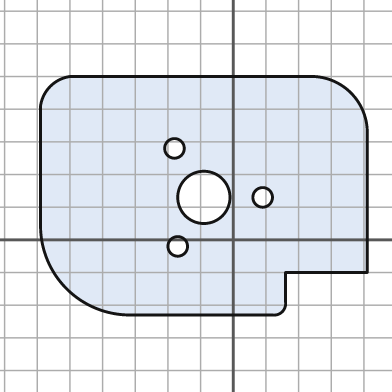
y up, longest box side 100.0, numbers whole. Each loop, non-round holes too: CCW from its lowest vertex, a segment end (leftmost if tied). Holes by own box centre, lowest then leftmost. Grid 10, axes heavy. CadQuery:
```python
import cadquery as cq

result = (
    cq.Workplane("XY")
    .moveTo(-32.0, -23.0)
    .lineTo(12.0, -23.0)
    .threePointArc((15.0, -22.0), (16.0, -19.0))
    .lineTo(16.0, -10.0)
    .lineTo(41.0, -10.0)
    .lineTo(41.0, 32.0)
    .threePointArc((36.0, 45.0), (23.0, 50.0))
    .lineTo(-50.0, 50.0)
    .threePointArc((-56.0, 47.0), (-59.0, 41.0))
    .lineTo(-59.0, 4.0)
    .threePointArc((-51.0, -15.0), (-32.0, -23.0))
    .close()
    .moveTo(-17.0, -2.0)
    .circle(3.0)
    .moveTo(-9.0, 13.0)
    .circle(8.0)
    .moveTo(9.0, 13.0)
    .circle(3.0)
    .moveTo(-18.0, 28.0)
    .circle(3.0)
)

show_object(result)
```